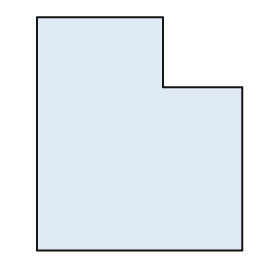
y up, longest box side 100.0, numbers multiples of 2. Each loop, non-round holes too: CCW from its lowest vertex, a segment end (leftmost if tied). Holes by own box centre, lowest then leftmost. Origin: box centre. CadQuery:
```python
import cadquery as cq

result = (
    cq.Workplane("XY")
    .moveTo(-44.0, -50.0)
    .lineTo(44.0, -50.0)
    .lineTo(44.0, 20.0)
    .lineTo(10.0, 20.0)
    .lineTo(10.0, 50.0)
    .lineTo(-44.0, 50.0)
    .close()
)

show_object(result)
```